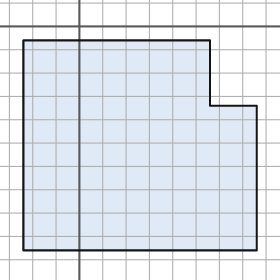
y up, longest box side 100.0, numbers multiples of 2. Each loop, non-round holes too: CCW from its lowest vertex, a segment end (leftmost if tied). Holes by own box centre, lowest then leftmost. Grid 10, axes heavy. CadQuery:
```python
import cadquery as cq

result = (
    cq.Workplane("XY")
    .moveTo(-24.0, -96.0)
    .lineTo(76.0, -96.0)
    .lineTo(76.0, -34.0)
    .lineTo(56.0, -34.0)
    .lineTo(56.0, -6.0)
    .lineTo(-24.0, -6.0)
    .close()
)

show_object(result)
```